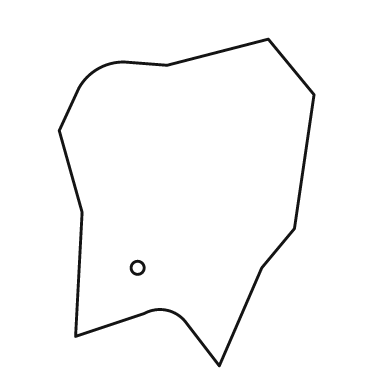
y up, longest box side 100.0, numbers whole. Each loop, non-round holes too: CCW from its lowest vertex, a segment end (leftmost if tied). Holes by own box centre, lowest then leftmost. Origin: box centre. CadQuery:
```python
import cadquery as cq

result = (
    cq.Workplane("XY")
    .moveTo(10.0, -50.0)
    .lineTo(23.0, -20.0)
    .lineTo(33.0, -8.0)
    .lineTo(39.0, 33.0)
    .lineTo(25.0, 50.0)
    .lineTo(-6.0, 42.0)
    .lineTo(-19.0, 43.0)
    .threePointArc((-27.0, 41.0), (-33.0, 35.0))
    .lineTo(-39.0, 22.0)
    .lineTo(-32.0, -3.0)
    .lineTo(-34.0, -41.0)
    .lineTo(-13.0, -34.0)
    .threePointArc((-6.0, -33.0), (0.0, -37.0))
    .close()
    .moveTo(-15.0, -20.0)
    .circle(2.0)
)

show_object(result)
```